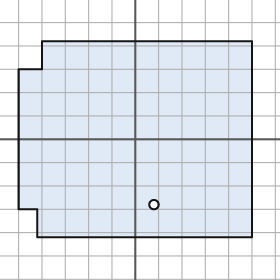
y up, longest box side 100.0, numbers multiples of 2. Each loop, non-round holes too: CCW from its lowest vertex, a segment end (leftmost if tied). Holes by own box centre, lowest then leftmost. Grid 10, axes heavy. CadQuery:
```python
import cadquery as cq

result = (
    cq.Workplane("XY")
    .moveTo(-42.0, -42.0)
    .lineTo(50.0, -42.0)
    .lineTo(50.0, 42.0)
    .lineTo(-40.0, 42.0)
    .lineTo(-40.0, 30.0)
    .lineTo(-50.0, 30.0)
    .lineTo(-50.0, -30.0)
    .lineTo(-42.0, -30.0)
    .close()
    .moveTo(8.0, -28.0)
    .circle(2.0)
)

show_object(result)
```